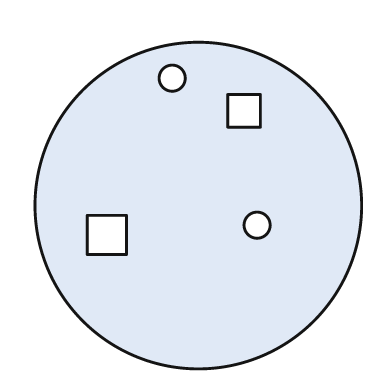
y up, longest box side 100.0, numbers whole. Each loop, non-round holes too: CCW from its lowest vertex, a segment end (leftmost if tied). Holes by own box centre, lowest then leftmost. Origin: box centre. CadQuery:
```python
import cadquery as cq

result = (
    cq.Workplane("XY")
    .moveTo(0.0, 0.0)
    .circle(50.0)
    .moveTo(-34.0, -15.0)
    .lineTo(-22.0, -15.0)
    .lineTo(-22.0, -3.0)
    .lineTo(-34.0, -3.0)
    .close()
    .moveTo(18.0, -6.0)
    .circle(4.0)
    .moveTo(9.0, 24.0)
    .lineTo(19.0, 24.0)
    .lineTo(19.0, 34.0)
    .lineTo(9.0, 34.0)
    .close()
    .moveTo(-8.0, 39.0)
    .circle(4.0)
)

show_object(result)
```